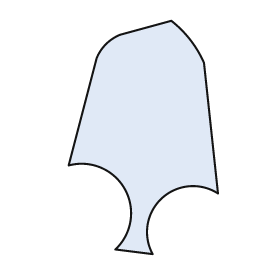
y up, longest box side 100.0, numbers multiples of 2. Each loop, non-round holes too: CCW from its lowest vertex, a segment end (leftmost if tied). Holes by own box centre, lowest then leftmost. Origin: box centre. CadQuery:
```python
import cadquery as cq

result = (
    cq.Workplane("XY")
    .moveTo(4.0, -50.0)
    .threePointArc((8.0, -26.0), (32.0, -24.0))
    .lineTo(26.0, 32.0)
    .threePointArc((20.0, 42.0), (12.0, 50.0))
    .lineTo(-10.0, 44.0)
    .threePointArc((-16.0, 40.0), (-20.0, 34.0))
    .lineTo(-32.0, -12.0)
    .threePointArc((-8.0, -22.0), (-12.0, -48.0))
    .close()
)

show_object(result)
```